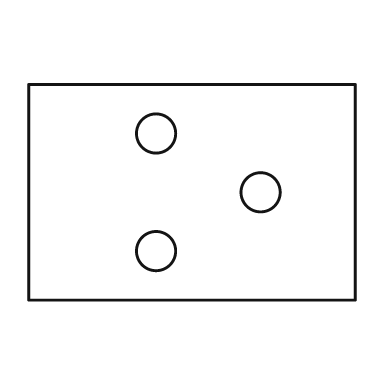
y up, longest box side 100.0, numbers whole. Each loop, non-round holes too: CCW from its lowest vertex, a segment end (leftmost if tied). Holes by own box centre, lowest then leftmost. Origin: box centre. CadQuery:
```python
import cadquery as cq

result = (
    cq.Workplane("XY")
    .moveTo(-50.0, -33.0)
    .lineTo(50.0, -33.0)
    .lineTo(50.0, 33.0)
    .lineTo(-50.0, 33.0)
    .close()
    .moveTo(-11.0, -18.0)
    .circle(6.0)
    .moveTo(21.0, 0.0)
    .circle(6.0)
    .moveTo(-11.0, 18.0)
    .circle(6.0)
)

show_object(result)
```